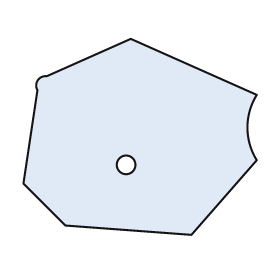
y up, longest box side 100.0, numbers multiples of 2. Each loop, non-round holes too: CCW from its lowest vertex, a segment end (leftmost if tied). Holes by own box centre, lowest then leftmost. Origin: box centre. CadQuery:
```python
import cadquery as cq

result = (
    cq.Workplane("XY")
    .moveTo(22.0, -42.0)
    .lineTo(50.0, -10.0)
    .threePointArc((46.0, 4.0), (50.0, 18.0))
    .lineTo(-4.0, 42.0)
    .lineTo(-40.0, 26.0)
    .threePointArc((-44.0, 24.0), (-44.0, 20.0))
    .lineTo(-50.0, -20.0)
    .lineTo(-32.0, -38.0)
    .close()
    .moveTo(-6.0, -12.0)
    .circle(4.0)
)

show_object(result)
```